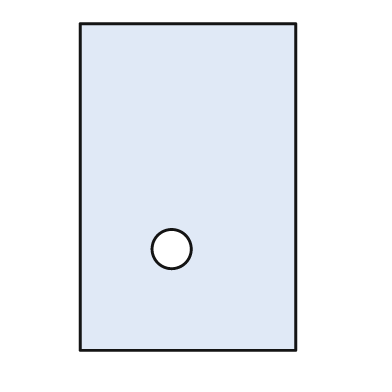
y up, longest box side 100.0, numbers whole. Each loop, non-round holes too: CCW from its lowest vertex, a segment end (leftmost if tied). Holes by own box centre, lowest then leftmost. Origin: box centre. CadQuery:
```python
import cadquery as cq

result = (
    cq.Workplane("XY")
    .moveTo(-33.0, -50.0)
    .lineTo(33.0, -50.0)
    .lineTo(33.0, 50.0)
    .lineTo(-33.0, 50.0)
    .close()
    .moveTo(-5.0, -19.0)
    .circle(6.0)
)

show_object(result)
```